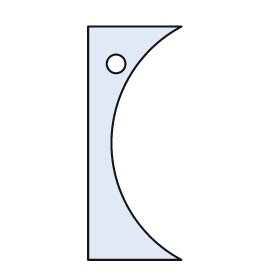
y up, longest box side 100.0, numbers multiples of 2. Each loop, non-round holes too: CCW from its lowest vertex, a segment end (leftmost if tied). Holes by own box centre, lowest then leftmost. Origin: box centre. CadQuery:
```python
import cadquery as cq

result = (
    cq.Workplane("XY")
    .moveTo(-20.0, -50.0)
    .lineTo(20.0, -50.0)
    .threePointArc((-10.0, 0.0), (20.0, 50.0))
    .lineTo(-20.0, 50.0)
    .close()
    .moveTo(-8.0, 34.0)
    .circle(4.0)
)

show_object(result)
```